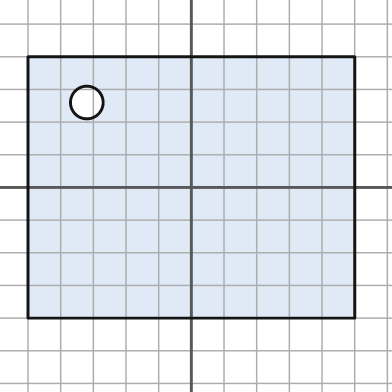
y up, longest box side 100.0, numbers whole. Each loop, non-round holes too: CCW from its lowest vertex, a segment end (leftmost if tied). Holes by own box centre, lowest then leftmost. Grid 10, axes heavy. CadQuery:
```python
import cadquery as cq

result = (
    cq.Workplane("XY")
    .moveTo(-50.0, -40.0)
    .lineTo(50.0, -40.0)
    .lineTo(50.0, 40.0)
    .lineTo(-50.0, 40.0)
    .close()
    .moveTo(-32.0, 26.0)
    .circle(5.0)
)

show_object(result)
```